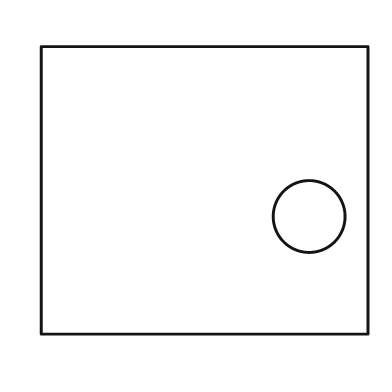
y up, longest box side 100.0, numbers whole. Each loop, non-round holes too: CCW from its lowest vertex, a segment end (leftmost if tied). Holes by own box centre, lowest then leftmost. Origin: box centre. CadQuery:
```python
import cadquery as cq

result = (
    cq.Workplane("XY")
    .moveTo(-50.0, -44.0)
    .lineTo(50.0, -44.0)
    .lineTo(50.0, 44.0)
    .lineTo(-50.0, 44.0)
    .close()
    .moveTo(32.0, -8.0)
    .circle(11.0)
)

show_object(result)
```